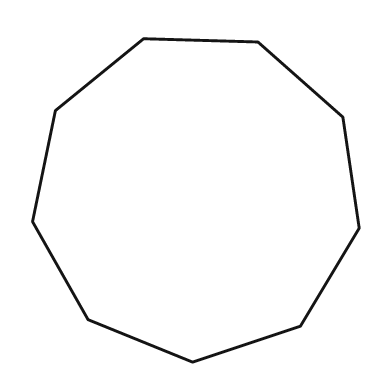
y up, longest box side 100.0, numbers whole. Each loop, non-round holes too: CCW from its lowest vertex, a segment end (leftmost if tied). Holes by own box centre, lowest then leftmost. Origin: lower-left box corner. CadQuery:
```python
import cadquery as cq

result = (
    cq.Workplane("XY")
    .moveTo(49.0, 0.0)
    .lineTo(82.0, 11.0)
    .lineTo(100.0, 41.0)
    .lineTo(95.0, 75.0)
    .lineTo(69.0, 98.0)
    .lineTo(34.0, 99.0)
    .lineTo(7.0, 77.0)
    .lineTo(0.0, 43.0)
    .lineTo(17.0, 13.0)
    .close()
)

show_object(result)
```